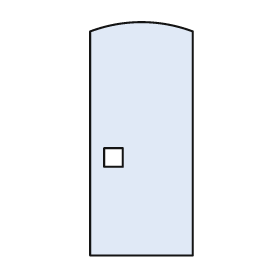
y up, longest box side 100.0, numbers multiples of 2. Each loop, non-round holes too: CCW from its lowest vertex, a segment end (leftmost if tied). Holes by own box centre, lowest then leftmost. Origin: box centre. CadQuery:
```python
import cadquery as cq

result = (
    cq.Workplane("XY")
    .moveTo(-22.0, -50.0)
    .lineTo(22.0, -50.0)
    .lineTo(22.0, 46.0)
    .threePointArc((0.0, 50.0), (-22.0, 46.0))
    .close()
    .moveTo(-16.0, -12.0)
    .lineTo(-8.0, -12.0)
    .lineTo(-8.0, -4.0)
    .lineTo(-16.0, -4.0)
    .close()
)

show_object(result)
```